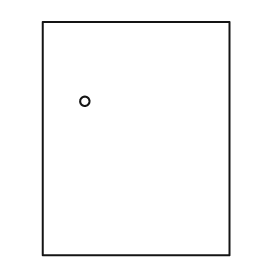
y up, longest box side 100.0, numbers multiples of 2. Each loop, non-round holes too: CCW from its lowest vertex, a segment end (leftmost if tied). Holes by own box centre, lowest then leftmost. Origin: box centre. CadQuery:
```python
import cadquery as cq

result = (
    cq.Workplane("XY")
    .moveTo(-40.0, -50.0)
    .lineTo(40.0, -50.0)
    .lineTo(40.0, 50.0)
    .lineTo(-40.0, 50.0)
    .close()
    .moveTo(-22.0, 16.0)
    .circle(2.0)
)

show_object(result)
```